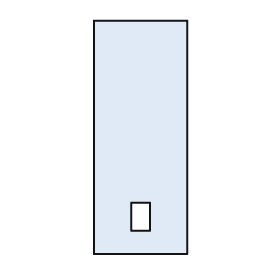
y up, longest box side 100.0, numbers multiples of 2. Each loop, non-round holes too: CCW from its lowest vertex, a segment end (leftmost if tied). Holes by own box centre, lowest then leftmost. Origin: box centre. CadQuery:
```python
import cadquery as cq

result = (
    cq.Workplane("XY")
    .moveTo(-20.0, -50.0)
    .lineTo(20.0, -50.0)
    .lineTo(20.0, 50.0)
    .lineTo(-20.0, 50.0)
    .close()
    .moveTo(-4.0, -40.0)
    .lineTo(4.0, -40.0)
    .lineTo(4.0, -28.0)
    .lineTo(-4.0, -28.0)
    .close()
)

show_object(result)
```